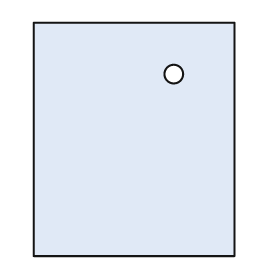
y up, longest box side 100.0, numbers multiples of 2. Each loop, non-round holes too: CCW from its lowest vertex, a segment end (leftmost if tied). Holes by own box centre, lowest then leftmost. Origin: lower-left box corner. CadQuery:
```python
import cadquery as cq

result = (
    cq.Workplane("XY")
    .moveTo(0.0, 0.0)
    .lineTo(86.0, 0.0)
    .lineTo(86.0, 100.0)
    .lineTo(0.0, 100.0)
    .close()
    .moveTo(60.0, 78.0)
    .circle(4.0)
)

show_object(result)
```